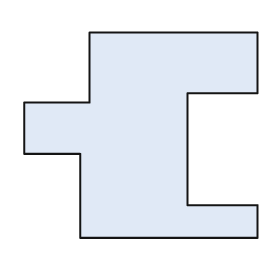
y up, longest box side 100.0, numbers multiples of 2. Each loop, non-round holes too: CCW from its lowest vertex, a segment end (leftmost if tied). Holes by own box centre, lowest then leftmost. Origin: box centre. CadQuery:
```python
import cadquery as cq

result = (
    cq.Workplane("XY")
    .moveTo(-26.0, -44.0)
    .lineTo(50.0, -44.0)
    .lineTo(50.0, -30.0)
    .lineTo(20.0, -30.0)
    .lineTo(20.0, 18.0)
    .lineTo(50.0, 18.0)
    .lineTo(50.0, 44.0)
    .lineTo(-22.0, 44.0)
    .lineTo(-22.0, 14.0)
    .lineTo(-50.0, 14.0)
    .lineTo(-50.0, -8.0)
    .lineTo(-26.0, -8.0)
    .close()
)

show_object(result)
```